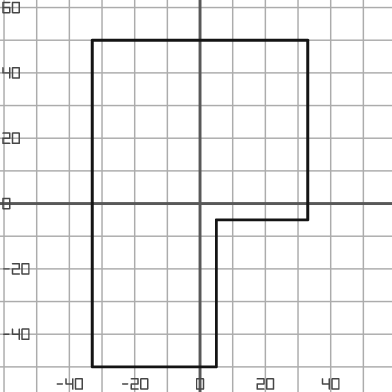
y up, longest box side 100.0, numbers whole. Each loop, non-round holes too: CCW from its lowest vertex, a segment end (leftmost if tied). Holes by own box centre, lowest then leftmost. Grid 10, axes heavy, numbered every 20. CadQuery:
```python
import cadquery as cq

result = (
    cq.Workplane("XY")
    .moveTo(-33.0, -50.0)
    .lineTo(5.0, -50.0)
    .lineTo(5.0, -5.0)
    .lineTo(33.0, -5.0)
    .lineTo(33.0, 50.0)
    .lineTo(-33.0, 50.0)
    .close()
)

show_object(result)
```